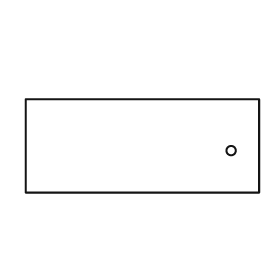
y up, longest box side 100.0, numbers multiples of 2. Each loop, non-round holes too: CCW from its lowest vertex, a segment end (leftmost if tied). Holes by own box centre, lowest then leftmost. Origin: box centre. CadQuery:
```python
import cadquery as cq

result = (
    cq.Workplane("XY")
    .moveTo(-50.0, -20.0)
    .lineTo(50.0, -20.0)
    .lineTo(50.0, 20.0)
    .lineTo(-50.0, 20.0)
    .close()
    .moveTo(38.0, -2.0)
    .circle(2.0)
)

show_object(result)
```